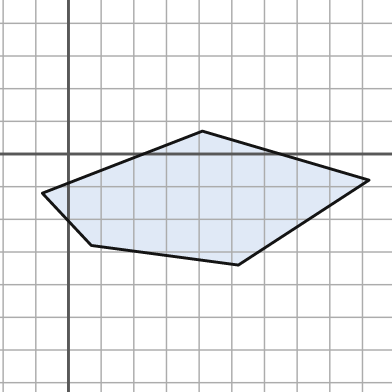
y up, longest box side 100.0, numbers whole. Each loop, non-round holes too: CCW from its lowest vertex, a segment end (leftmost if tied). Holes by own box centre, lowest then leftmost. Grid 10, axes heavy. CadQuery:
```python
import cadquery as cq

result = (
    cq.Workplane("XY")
    .moveTo(52.0, -34.0)
    .lineTo(92.0, -8.0)
    .lineTo(41.0, 7.0)
    .lineTo(-8.0, -12.0)
    .lineTo(7.0, -28.0)
    .close()
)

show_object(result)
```